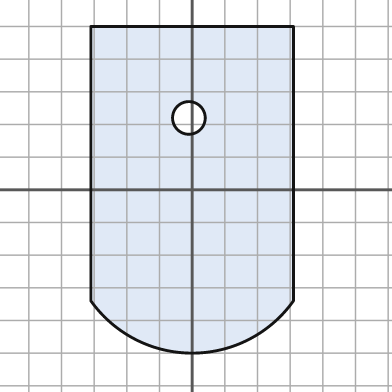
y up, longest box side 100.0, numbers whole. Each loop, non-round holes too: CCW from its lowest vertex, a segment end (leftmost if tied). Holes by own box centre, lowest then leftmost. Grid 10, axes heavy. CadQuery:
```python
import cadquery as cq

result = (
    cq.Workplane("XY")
    .moveTo(-31.0, -34.0)
    .threePointArc((0.0, -50.0), (31.0, -34.0))
    .lineTo(31.0, 50.0)
    .lineTo(-31.0, 50.0)
    .close()
    .moveTo(-1.0, 22.0)
    .circle(5.0)
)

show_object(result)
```